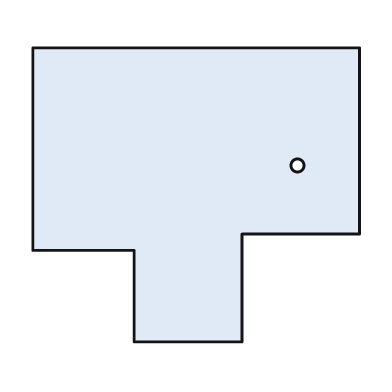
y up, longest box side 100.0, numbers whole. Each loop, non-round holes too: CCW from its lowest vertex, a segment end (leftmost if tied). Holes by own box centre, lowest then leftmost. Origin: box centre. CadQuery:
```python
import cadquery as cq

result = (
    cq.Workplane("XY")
    .moveTo(-19.0, -45.0)
    .lineTo(14.0, -45.0)
    .lineTo(14.0, -12.0)
    .lineTo(50.0, -12.0)
    .lineTo(50.0, 45.0)
    .lineTo(-50.0, 45.0)
    .lineTo(-50.0, -17.0)
    .lineTo(-19.0, -17.0)
    .close()
    .moveTo(31.0, 9.0)
    .circle(2.0)
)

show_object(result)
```